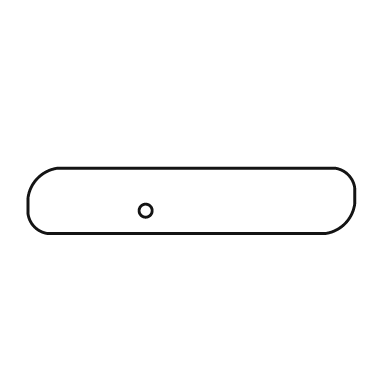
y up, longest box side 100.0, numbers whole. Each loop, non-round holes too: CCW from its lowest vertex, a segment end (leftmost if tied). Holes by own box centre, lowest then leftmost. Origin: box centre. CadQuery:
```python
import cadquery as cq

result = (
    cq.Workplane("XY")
    .moveTo(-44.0, -10.0)
    .lineTo(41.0, -10.0)
    .threePointArc((47.0, -7.0), (50.0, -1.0))
    .lineTo(50.0, 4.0)
    .threePointArc((48.0, 8.0), (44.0, 10.0))
    .lineTo(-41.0, 10.0)
    .threePointArc((-47.0, 7.0), (-50.0, 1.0))
    .lineTo(-50.0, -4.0)
    .threePointArc((-48.0, -8.0), (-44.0, -10.0))
    .close()
    .moveTo(-14.0, -3.0)
    .circle(2.0)
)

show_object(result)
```